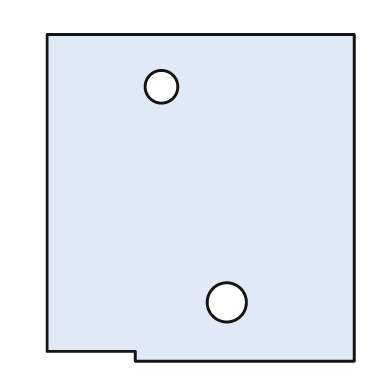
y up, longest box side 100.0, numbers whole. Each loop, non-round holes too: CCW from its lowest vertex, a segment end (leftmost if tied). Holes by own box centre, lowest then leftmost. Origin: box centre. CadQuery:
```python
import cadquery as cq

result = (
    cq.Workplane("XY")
    .moveTo(-20.0, -50.0)
    .lineTo(47.0, -50.0)
    .lineTo(47.0, 50.0)
    .lineTo(-47.0, 50.0)
    .lineTo(-47.0, -47.0)
    .lineTo(-20.0, -47.0)
    .close()
    .moveTo(8.0, -32.0)
    .circle(6.0)
    .moveTo(-12.0, 34.0)
    .circle(5.0)
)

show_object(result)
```